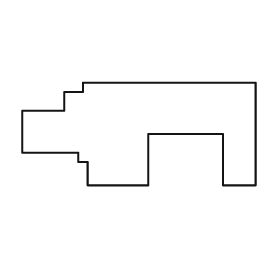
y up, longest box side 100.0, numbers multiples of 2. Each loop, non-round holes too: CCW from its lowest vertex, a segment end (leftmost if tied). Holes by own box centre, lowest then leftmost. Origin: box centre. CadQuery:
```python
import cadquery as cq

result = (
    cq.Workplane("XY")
    .moveTo(-22.0, -22.0)
    .lineTo(4.0, -22.0)
    .lineTo(4.0, 0.0)
    .lineTo(36.0, 0.0)
    .lineTo(36.0, -22.0)
    .lineTo(50.0, -22.0)
    .lineTo(50.0, 22.0)
    .lineTo(-24.0, 22.0)
    .lineTo(-24.0, 18.0)
    .lineTo(-32.0, 18.0)
    .lineTo(-32.0, 10.0)
    .lineTo(-50.0, 10.0)
    .lineTo(-50.0, -8.0)
    .lineTo(-26.0, -8.0)
    .lineTo(-26.0, -12.0)
    .lineTo(-22.0, -12.0)
    .close()
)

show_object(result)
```